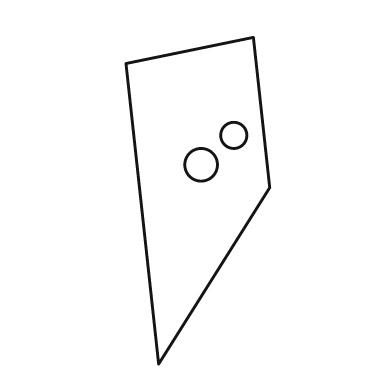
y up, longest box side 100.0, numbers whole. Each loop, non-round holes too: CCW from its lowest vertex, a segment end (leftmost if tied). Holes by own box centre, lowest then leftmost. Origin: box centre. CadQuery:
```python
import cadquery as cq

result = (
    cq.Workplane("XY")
    .moveTo(-12.0, -50.0)
    .lineTo(22.0, 4.0)
    .lineTo(17.0, 50.0)
    .lineTo(-22.0, 42.0)
    .close()
    .moveTo(1.0, 11.0)
    .circle(5.0)
    .moveTo(11.0, 20.0)
    .circle(4.0)
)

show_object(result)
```